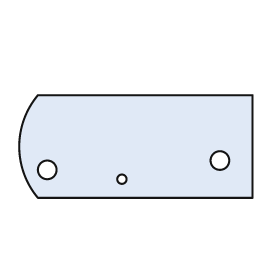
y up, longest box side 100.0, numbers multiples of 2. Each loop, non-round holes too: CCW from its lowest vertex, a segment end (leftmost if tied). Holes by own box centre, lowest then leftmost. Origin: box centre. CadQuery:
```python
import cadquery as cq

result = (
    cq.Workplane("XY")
    .moveTo(-42.0, -22.0)
    .lineTo(50.0, -22.0)
    .lineTo(50.0, 22.0)
    .lineTo(-42.0, 22.0)
    .threePointArc((-50.0, 0.0), (-42.0, -22.0))
    .close()
    .moveTo(-6.0, -14.0)
    .circle(2.0)
    .moveTo(-38.0, -10.0)
    .circle(4.0)
    .moveTo(36.0, -6.0)
    .circle(4.0)
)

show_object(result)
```